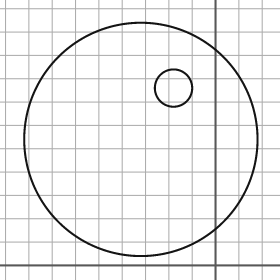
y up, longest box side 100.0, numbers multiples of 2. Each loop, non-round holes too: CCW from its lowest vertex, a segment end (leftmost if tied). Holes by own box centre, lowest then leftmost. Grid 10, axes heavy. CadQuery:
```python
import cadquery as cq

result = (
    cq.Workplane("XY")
    .moveTo(-32.0, 54.0)
    .circle(50.0)
    .moveTo(-18.0, 76.0)
    .circle(8.0)
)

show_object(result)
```